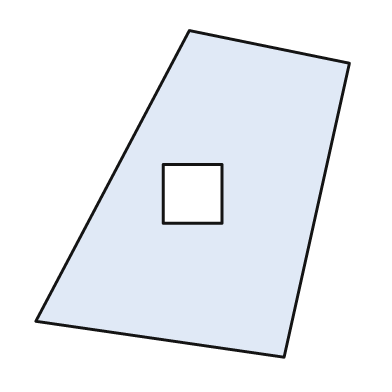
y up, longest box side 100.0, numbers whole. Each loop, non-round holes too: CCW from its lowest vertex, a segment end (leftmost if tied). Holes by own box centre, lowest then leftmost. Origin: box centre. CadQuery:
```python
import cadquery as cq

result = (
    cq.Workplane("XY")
    .moveTo(28.0, -50.0)
    .lineTo(48.0, 40.0)
    .lineTo(-1.0, 50.0)
    .lineTo(-48.0, -39.0)
    .close()
    .moveTo(-9.0, -9.0)
    .lineTo(9.0, -9.0)
    .lineTo(9.0, 9.0)
    .lineTo(-9.0, 9.0)
    .close()
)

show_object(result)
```